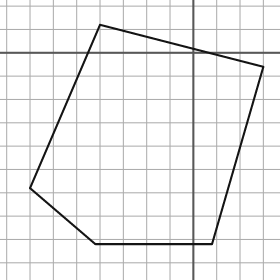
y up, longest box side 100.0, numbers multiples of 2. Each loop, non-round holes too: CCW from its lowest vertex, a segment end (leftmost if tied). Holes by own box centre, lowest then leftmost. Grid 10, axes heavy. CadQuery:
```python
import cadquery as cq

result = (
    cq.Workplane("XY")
    .moveTo(-42.0, -82.0)
    .lineTo(8.0, -82.0)
    .lineTo(30.0, -6.0)
    .lineTo(-40.0, 12.0)
    .lineTo(-70.0, -58.0)
    .close()
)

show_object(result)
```